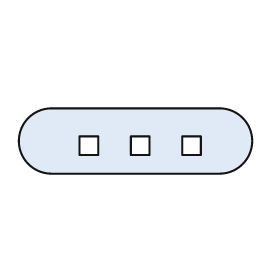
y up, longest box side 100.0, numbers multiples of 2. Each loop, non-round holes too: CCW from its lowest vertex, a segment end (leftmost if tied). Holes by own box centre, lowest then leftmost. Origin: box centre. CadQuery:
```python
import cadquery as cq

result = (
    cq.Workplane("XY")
    .moveTo(-36.0, -14.0)
    .lineTo(36.0, -14.0)
    .threePointArc((50.0, 0.0), (36.0, 14.0))
    .lineTo(-36.0, 14.0)
    .threePointArc((-50.0, 0.0), (-36.0, -14.0))
    .close()
    .moveTo(-24.0, -6.0)
    .lineTo(-16.0, -6.0)
    .lineTo(-16.0, 2.0)
    .lineTo(-24.0, 2.0)
    .close()
    .moveTo(-2.0, -6.0)
    .lineTo(6.0, -6.0)
    .lineTo(6.0, 2.0)
    .lineTo(-2.0, 2.0)
    .close()
    .moveTo(20.0, -6.0)
    .lineTo(28.0, -6.0)
    .lineTo(28.0, 2.0)
    .lineTo(20.0, 2.0)
    .close()
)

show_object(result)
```